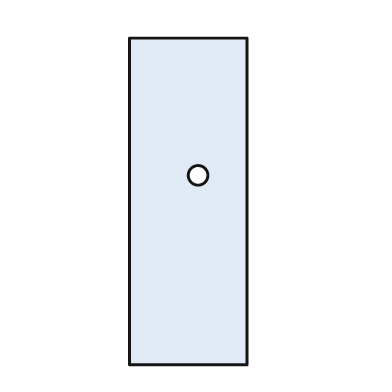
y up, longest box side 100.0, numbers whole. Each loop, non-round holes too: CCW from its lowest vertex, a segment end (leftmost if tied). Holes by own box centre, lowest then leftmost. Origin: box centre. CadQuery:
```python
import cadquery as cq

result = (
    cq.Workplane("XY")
    .moveTo(-18.0, -50.0)
    .lineTo(18.0, -50.0)
    .lineTo(18.0, 50.0)
    .lineTo(-18.0, 50.0)
    .close()
    .moveTo(3.0, 8.0)
    .circle(3.0)
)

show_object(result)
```